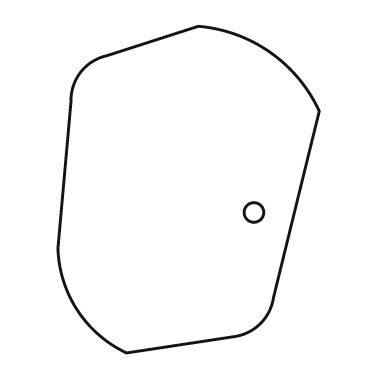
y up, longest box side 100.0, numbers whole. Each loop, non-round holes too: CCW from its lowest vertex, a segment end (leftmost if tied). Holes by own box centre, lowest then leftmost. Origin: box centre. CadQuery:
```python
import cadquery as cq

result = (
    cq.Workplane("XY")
    .moveTo(-19.0, -50.0)
    .lineTo(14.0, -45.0)
    .threePointArc((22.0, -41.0), (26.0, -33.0))
    .lineTo(40.0, 24.0)
    .threePointArc((25.0, 42.0), (3.0, 50.0))
    .lineTo(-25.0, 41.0)
    .threePointArc((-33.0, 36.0), (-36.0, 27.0))
    .lineTo(-40.0, -18.0)
    .threePointArc((-34.0, -37.0), (-19.0, -50.0))
    .close()
    .moveTo(20.0, -7.0)
    .circle(3.0)
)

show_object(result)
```